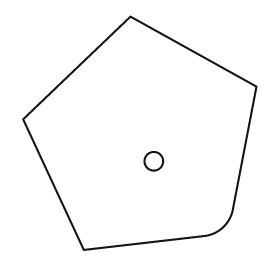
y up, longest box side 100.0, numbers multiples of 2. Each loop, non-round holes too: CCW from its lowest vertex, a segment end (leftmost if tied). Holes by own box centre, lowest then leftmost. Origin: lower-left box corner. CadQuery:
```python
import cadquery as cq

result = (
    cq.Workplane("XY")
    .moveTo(26.0, 0.0)
    .lineTo(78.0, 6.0)
    .threePointArc((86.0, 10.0), (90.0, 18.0))
    .lineTo(100.0, 70.0)
    .lineTo(46.0, 100.0)
    .lineTo(0.0, 56.0)
    .close()
    .moveTo(56.0, 38.0)
    .circle(4.0)
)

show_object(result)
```